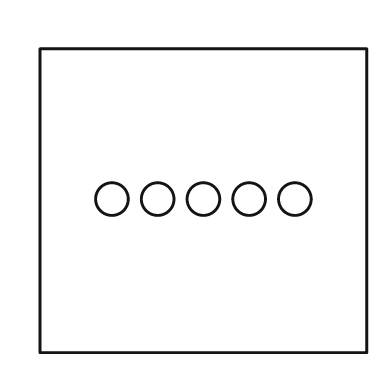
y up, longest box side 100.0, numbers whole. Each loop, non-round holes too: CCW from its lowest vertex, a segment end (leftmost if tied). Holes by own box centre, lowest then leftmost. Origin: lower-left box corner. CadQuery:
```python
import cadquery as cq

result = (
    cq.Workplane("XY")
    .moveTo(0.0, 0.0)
    .lineTo(100.0, 0.0)
    .lineTo(100.0, 93.0)
    .lineTo(0.0, 93.0)
    .close()
    .moveTo(22.0, 47.0)
    .circle(5.0)
    .moveTo(36.0, 47.0)
    .circle(5.0)
    .moveTo(50.0, 47.0)
    .circle(5.0)
    .moveTo(64.0, 47.0)
    .circle(5.0)
    .moveTo(78.0, 47.0)
    .circle(5.0)
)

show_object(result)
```